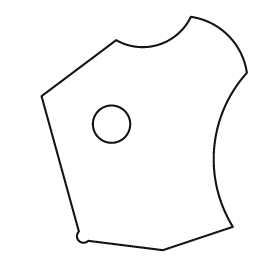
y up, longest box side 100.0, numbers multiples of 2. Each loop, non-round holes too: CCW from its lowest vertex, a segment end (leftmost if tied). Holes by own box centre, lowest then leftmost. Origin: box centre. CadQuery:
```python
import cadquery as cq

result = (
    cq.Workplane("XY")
    .moveTo(8.0, -50.0)
    .lineTo(38.0, -40.0)
    .threePointArc((30.0, -6.0), (44.0, 26.0))
    .threePointArc((36.0, 42.0), (20.0, 50.0))
    .threePointArc((6.0, 38.0), (-12.0, 40.0))
    .lineTo(-44.0, 16.0)
    .lineTo(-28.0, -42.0)
    .threePointArc((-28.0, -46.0), (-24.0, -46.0))
    .close()
    .moveTo(-14.0, 4.0)
    .circle(8.0)
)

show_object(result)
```